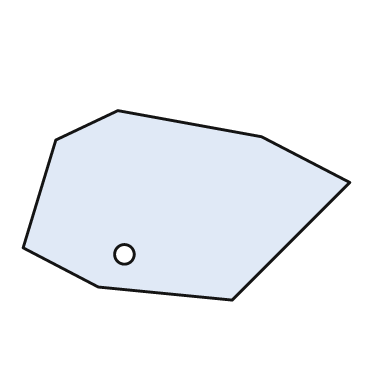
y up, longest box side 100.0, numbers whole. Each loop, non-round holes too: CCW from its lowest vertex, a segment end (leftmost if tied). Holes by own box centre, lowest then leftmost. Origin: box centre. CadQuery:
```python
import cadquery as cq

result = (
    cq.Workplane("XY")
    .moveTo(14.0, -29.0)
    .lineTo(50.0, 7.0)
    .lineTo(23.0, 21.0)
    .lineTo(-21.0, 29.0)
    .lineTo(-40.0, 20.0)
    .lineTo(-50.0, -13.0)
    .lineTo(-27.0, -25.0)
    .close()
    .moveTo(-19.0, -15.0)
    .circle(3.0)
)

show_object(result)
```